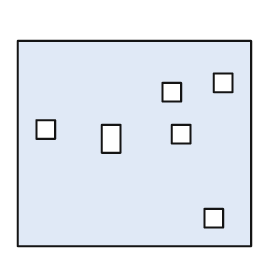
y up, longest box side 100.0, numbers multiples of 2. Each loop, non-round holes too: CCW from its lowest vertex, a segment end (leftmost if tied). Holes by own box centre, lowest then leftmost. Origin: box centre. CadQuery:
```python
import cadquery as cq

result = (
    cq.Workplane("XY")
    .moveTo(-50.0, -44.0)
    .lineTo(50.0, -44.0)
    .lineTo(50.0, 44.0)
    .lineTo(-50.0, 44.0)
    .close()
    .moveTo(30.0, -36.0)
    .lineTo(38.0, -36.0)
    .lineTo(38.0, -28.0)
    .lineTo(30.0, -28.0)
    .close()
    .moveTo(-14.0, -4.0)
    .lineTo(-6.0, -4.0)
    .lineTo(-6.0, 8.0)
    .lineTo(-14.0, 8.0)
    .close()
    .moveTo(16.0, 0.0)
    .lineTo(24.0, 0.0)
    .lineTo(24.0, 8.0)
    .lineTo(16.0, 8.0)
    .close()
    .moveTo(-42.0, 2.0)
    .lineTo(-34.0, 2.0)
    .lineTo(-34.0, 10.0)
    .lineTo(-42.0, 10.0)
    .close()
    .moveTo(12.0, 18.0)
    .lineTo(20.0, 18.0)
    .lineTo(20.0, 26.0)
    .lineTo(12.0, 26.0)
    .close()
    .moveTo(34.0, 22.0)
    .lineTo(42.0, 22.0)
    .lineTo(42.0, 30.0)
    .lineTo(34.0, 30.0)
    .close()
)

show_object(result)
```